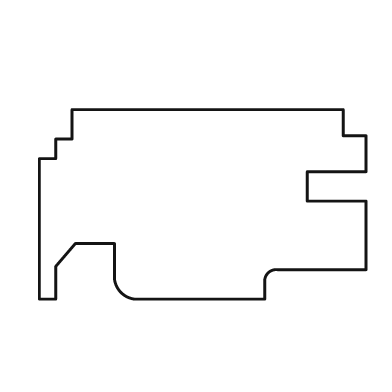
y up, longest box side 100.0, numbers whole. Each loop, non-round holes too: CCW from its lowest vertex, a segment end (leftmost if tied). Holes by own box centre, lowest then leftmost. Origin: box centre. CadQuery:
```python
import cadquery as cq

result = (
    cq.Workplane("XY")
    .moveTo(-50.0, -29.0)
    .lineTo(-45.0, -29.0)
    .lineTo(-45.0, -19.0)
    .lineTo(-39.0, -12.0)
    .lineTo(-27.0, -12.0)
    .lineTo(-27.0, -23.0)
    .threePointArc((-25.0, -27.0), (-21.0, -29.0))
    .lineTo(19.0, -29.0)
    .lineTo(19.0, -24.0)
    .threePointArc((20.0, -21.0), (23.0, -20.0))
    .lineTo(50.0, -20.0)
    .lineTo(50.0, 1.0)
    .lineTo(32.0, 1.0)
    .lineTo(32.0, 10.0)
    .lineTo(50.0, 10.0)
    .lineTo(50.0, 21.0)
    .lineTo(43.0, 21.0)
    .lineTo(43.0, 29.0)
    .lineTo(-40.0, 29.0)
    .lineTo(-40.0, 20.0)
    .lineTo(-45.0, 20.0)
    .lineTo(-45.0, 14.0)
    .lineTo(-50.0, 14.0)
    .close()
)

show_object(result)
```